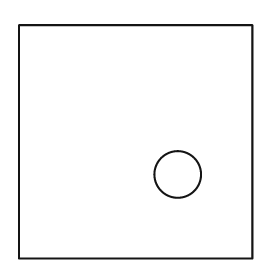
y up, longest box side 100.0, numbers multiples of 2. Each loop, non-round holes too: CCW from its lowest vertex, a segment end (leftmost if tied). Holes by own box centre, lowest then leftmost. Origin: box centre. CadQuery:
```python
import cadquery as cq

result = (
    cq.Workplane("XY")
    .moveTo(-50.0, -50.0)
    .lineTo(50.0, -50.0)
    .lineTo(50.0, 50.0)
    .lineTo(-50.0, 50.0)
    .close()
    .moveTo(18.0, -14.0)
    .circle(10.0)
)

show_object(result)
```